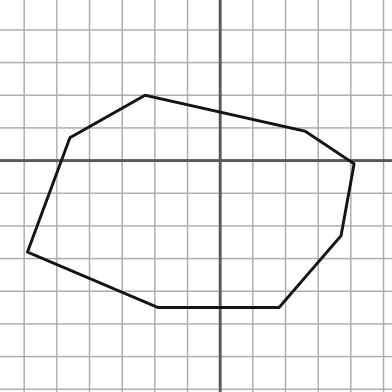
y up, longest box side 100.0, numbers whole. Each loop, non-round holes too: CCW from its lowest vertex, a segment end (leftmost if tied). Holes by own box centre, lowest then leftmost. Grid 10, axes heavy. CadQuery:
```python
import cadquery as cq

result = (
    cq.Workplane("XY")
    .moveTo(-19.0, -45.0)
    .lineTo(18.0, -45.0)
    .lineTo(37.0, -23.0)
    .lineTo(41.0, -1.0)
    .lineTo(26.0, 9.0)
    .lineTo(-23.0, 20.0)
    .lineTo(-46.0, 7.0)
    .lineTo(-59.0, -28.0)
    .close()
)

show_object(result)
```